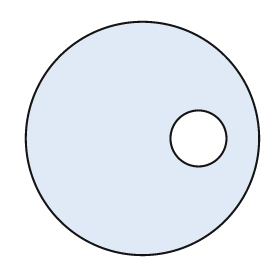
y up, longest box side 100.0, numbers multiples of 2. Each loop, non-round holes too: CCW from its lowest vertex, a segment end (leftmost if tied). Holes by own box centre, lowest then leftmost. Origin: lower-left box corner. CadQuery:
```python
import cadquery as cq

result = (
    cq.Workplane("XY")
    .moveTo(50.0, 50.0)
    .circle(50.0)
    .moveTo(74.0, 50.0)
    .circle(12.0)
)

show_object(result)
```